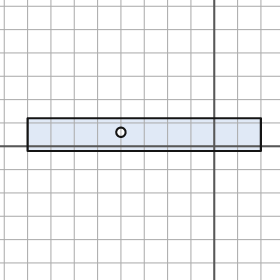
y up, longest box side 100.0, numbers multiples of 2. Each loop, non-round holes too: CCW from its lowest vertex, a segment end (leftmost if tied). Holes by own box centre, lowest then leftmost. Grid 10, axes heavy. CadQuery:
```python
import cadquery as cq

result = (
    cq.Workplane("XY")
    .moveTo(-80.0, -2.0)
    .lineTo(20.0, -2.0)
    .lineTo(20.0, 12.0)
    .lineTo(-80.0, 12.0)
    .close()
    .moveTo(-40.0, 6.0)
    .circle(2.0)
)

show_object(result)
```